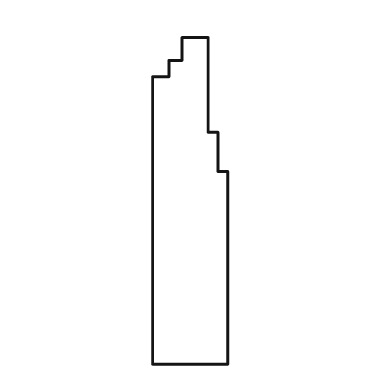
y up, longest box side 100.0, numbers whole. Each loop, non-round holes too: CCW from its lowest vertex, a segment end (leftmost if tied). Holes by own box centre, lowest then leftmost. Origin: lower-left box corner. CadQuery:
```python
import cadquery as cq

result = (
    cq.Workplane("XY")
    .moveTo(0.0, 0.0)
    .lineTo(23.0, 0.0)
    .lineTo(23.0, 59.0)
    .lineTo(20.0, 59.0)
    .lineTo(20.0, 71.0)
    .lineTo(17.0, 71.0)
    .lineTo(17.0, 100.0)
    .lineTo(9.0, 100.0)
    .lineTo(9.0, 93.0)
    .lineTo(5.0, 93.0)
    .lineTo(5.0, 88.0)
    .lineTo(0.0, 88.0)
    .close()
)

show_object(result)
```